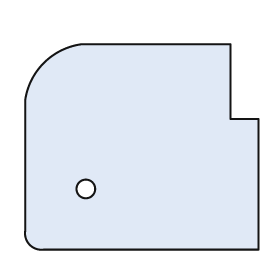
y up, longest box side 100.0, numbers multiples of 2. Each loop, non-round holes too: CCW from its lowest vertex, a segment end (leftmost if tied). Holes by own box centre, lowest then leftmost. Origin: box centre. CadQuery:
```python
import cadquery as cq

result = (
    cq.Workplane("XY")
    .moveTo(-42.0, -44.0)
    .lineTo(50.0, -44.0)
    .lineTo(50.0, 12.0)
    .lineTo(38.0, 12.0)
    .lineTo(38.0, 44.0)
    .lineTo(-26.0, 44.0)
    .threePointArc((-42.0, 36.0), (-50.0, 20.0))
    .lineTo(-50.0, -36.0)
    .threePointArc((-48.0, -42.0), (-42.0, -44.0))
    .close()
    .moveTo(-24.0, -18.0)
    .circle(4.0)
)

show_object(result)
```